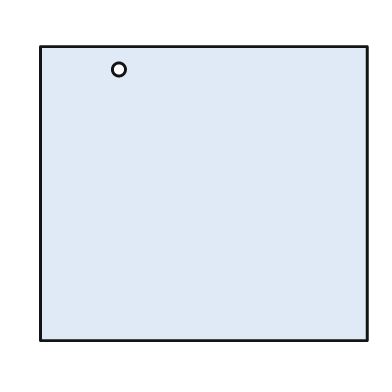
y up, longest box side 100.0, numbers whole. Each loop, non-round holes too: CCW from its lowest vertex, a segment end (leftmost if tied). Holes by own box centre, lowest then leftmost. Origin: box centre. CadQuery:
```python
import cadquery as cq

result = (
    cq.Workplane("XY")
    .moveTo(-50.0, -45.0)
    .lineTo(50.0, -45.0)
    .lineTo(50.0, 45.0)
    .lineTo(-50.0, 45.0)
    .close()
    .moveTo(-26.0, 38.0)
    .circle(2.0)
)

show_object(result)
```